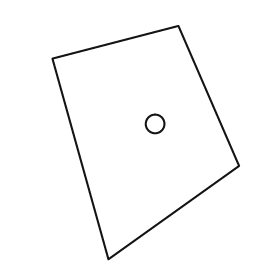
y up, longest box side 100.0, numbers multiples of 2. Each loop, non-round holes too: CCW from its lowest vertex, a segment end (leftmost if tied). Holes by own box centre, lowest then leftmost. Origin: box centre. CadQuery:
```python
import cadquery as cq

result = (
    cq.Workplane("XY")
    .moveTo(-16.0, -50.0)
    .lineTo(40.0, -10.0)
    .lineTo(14.0, 50.0)
    .lineTo(-40.0, 36.0)
    .close()
    .moveTo(4.0, 8.0)
    .circle(4.0)
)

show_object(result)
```